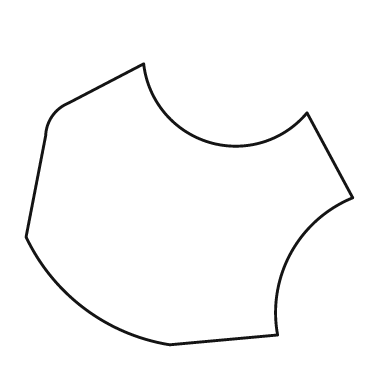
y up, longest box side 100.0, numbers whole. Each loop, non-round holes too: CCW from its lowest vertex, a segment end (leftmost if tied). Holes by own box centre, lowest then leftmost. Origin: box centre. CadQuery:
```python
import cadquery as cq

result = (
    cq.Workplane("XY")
    .moveTo(-6.0, -43.0)
    .lineTo(27.0, -40.0)
    .threePointArc((31.0, -15.0), (50.0, 2.0))
    .lineTo(36.0, 28.0)
    .threePointArc((6.0, 19.0), (-14.0, 43.0))
    .lineTo(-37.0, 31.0)
    .threePointArc((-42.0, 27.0), (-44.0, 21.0))
    .lineTo(-50.0, -10.0)
    .threePointArc((-32.0, -32.0), (-6.0, -43.0))
    .close()
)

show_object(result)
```